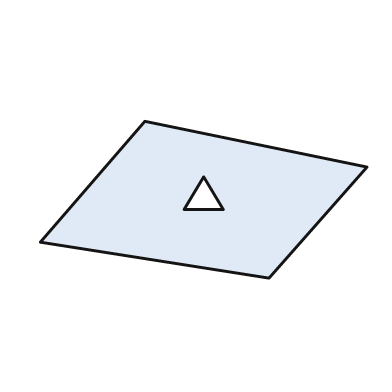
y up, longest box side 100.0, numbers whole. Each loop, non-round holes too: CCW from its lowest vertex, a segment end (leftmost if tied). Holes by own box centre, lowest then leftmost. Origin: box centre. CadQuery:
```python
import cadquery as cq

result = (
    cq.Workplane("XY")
    .moveTo(20.0, -24.0)
    .lineTo(50.0, 10.0)
    .lineTo(-18.0, 24.0)
    .lineTo(-50.0, -13.0)
    .close()
    .moveTo(-6.0, -3.0)
    .lineTo(6.0, -3.0)
    .lineTo(0.0, 7.0)
    .close()
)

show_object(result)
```